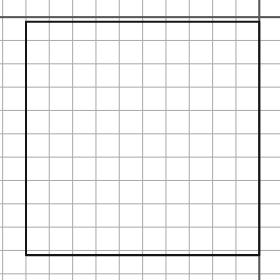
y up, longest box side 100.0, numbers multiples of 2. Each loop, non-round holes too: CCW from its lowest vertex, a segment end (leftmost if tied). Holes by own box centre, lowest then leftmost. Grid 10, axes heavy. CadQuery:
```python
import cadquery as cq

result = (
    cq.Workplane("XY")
    .moveTo(-100.0, -102.0)
    .lineTo(0.0, -102.0)
    .lineTo(0.0, -2.0)
    .lineTo(-100.0, -2.0)
    .close()
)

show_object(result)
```